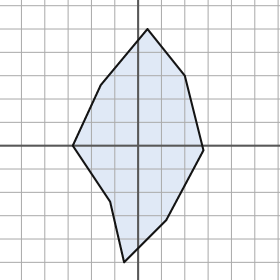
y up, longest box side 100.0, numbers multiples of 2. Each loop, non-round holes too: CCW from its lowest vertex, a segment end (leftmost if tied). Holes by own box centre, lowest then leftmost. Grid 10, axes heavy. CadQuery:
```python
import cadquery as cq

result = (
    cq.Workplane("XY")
    .moveTo(-6.0, -50.0)
    .lineTo(12.0, -32.0)
    .lineTo(28.0, -2.0)
    .lineTo(20.0, 30.0)
    .lineTo(4.0, 50.0)
    .lineTo(-16.0, 26.0)
    .lineTo(-28.0, 0.0)
    .lineTo(-12.0, -24.0)
    .close()
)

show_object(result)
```